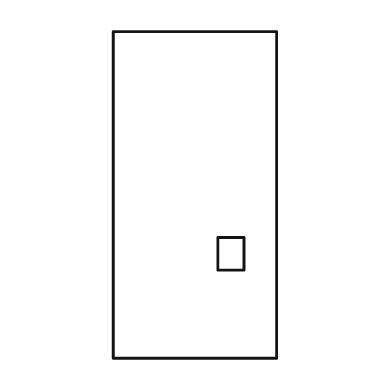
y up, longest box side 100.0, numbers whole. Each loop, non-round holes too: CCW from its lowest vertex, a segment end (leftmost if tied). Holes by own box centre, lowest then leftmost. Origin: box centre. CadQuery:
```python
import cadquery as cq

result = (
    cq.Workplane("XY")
    .moveTo(-25.0, -50.0)
    .lineTo(25.0, -50.0)
    .lineTo(25.0, 50.0)
    .lineTo(-25.0, 50.0)
    .close()
    .moveTo(7.0, -23.0)
    .lineTo(15.0, -23.0)
    .lineTo(15.0, -13.0)
    .lineTo(7.0, -13.0)
    .close()
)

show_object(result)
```